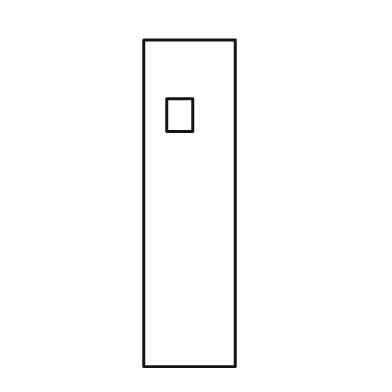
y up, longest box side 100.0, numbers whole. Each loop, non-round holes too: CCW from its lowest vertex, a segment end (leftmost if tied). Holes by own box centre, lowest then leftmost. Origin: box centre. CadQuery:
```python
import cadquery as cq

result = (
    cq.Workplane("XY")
    .moveTo(-14.0, -50.0)
    .lineTo(14.0, -50.0)
    .lineTo(14.0, 50.0)
    .lineTo(-14.0, 50.0)
    .close()
    .moveTo(-7.0, 22.0)
    .lineTo(1.0, 22.0)
    .lineTo(1.0, 32.0)
    .lineTo(-7.0, 32.0)
    .close()
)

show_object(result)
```